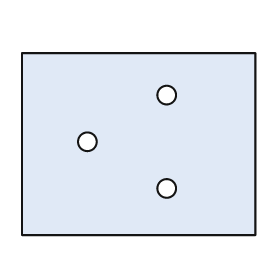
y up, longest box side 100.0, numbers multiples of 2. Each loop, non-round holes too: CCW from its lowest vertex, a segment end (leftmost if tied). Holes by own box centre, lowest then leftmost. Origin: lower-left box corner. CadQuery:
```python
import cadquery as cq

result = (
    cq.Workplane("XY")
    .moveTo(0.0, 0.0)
    .lineTo(100.0, 0.0)
    .lineTo(100.0, 78.0)
    .lineTo(0.0, 78.0)
    .close()
    .moveTo(62.0, 20.0)
    .circle(4.0)
    .moveTo(28.0, 40.0)
    .circle(4.0)
    .moveTo(62.0, 60.0)
    .circle(4.0)
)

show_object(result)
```